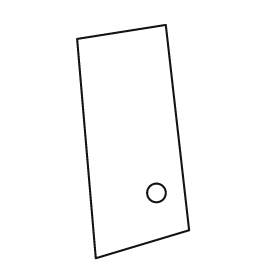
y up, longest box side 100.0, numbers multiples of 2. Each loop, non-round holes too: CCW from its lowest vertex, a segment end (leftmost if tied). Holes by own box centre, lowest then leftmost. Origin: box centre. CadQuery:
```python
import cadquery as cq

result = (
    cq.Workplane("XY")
    .moveTo(-16.0, -50.0)
    .lineTo(24.0, -38.0)
    .lineTo(14.0, 50.0)
    .lineTo(-24.0, 44.0)
    .close()
    .moveTo(10.0, -22.0)
    .circle(4.0)
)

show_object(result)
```